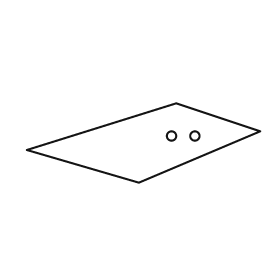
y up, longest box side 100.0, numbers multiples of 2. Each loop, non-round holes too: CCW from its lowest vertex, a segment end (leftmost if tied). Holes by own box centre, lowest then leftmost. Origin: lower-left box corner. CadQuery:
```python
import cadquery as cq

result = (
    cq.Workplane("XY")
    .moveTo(48.0, 0.0)
    .lineTo(100.0, 22.0)
    .lineTo(64.0, 34.0)
    .lineTo(0.0, 14.0)
    .close()
    .moveTo(62.0, 20.0)
    .circle(2.0)
    .moveTo(72.0, 20.0)
    .circle(2.0)
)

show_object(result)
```